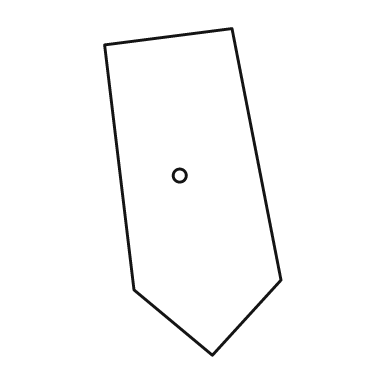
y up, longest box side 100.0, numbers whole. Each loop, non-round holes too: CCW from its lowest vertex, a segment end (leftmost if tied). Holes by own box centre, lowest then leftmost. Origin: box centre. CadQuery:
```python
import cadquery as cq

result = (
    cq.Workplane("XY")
    .moveTo(6.0, -50.0)
    .lineTo(27.0, -27.0)
    .lineTo(12.0, 50.0)
    .lineTo(-27.0, 45.0)
    .lineTo(-18.0, -30.0)
    .close()
    .moveTo(-4.0, 5.0)
    .circle(2.0)
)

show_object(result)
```